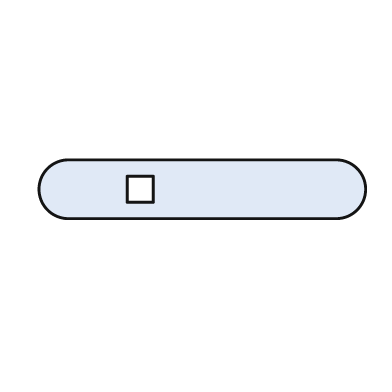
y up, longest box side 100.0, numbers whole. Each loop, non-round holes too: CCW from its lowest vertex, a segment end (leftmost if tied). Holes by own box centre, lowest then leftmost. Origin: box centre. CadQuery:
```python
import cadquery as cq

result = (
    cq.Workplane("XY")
    .moveTo(-41.0, -9.0)
    .lineTo(41.0, -9.0)
    .threePointArc((50.0, 0.0), (41.0, 9.0))
    .lineTo(-41.0, 9.0)
    .threePointArc((-50.0, 0.0), (-41.0, -9.0))
    .close()
    .moveTo(-23.0, -4.0)
    .lineTo(-15.0, -4.0)
    .lineTo(-15.0, 4.0)
    .lineTo(-23.0, 4.0)
    .close()
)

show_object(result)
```